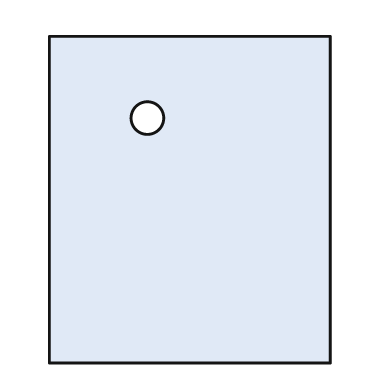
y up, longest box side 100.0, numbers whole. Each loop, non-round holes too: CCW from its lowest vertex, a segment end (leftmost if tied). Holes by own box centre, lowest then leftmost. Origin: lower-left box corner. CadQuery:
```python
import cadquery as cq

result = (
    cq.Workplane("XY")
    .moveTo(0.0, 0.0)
    .lineTo(86.0, 0.0)
    .lineTo(86.0, 100.0)
    .lineTo(0.0, 100.0)
    .close()
    .moveTo(30.0, 75.0)
    .circle(5.0)
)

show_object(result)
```